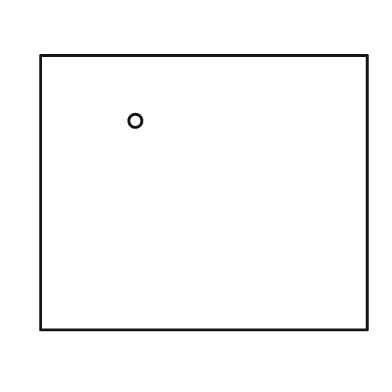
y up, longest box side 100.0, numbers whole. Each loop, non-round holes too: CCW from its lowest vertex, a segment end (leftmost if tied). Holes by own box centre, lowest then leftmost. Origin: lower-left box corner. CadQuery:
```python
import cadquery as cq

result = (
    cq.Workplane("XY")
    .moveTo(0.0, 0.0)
    .lineTo(100.0, 0.0)
    .lineTo(100.0, 84.0)
    .lineTo(0.0, 84.0)
    .close()
    .moveTo(29.0, 64.0)
    .circle(2.0)
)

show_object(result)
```